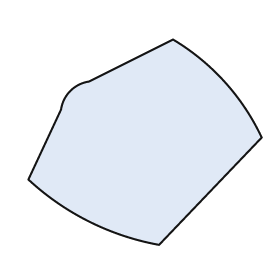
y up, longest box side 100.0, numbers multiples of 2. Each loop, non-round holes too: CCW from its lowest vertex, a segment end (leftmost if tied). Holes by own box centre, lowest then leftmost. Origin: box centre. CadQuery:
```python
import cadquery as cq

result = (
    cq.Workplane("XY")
    .moveTo(6.0, -44.0)
    .lineTo(50.0, 2.0)
    .threePointArc((34.0, 26.0), (12.0, 44.0))
    .lineTo(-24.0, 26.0)
    .threePointArc((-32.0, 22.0), (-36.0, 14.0))
    .lineTo(-50.0, -16.0)
    .threePointArc((-24.0, -34.0), (6.0, -44.0))
    .close()
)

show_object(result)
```